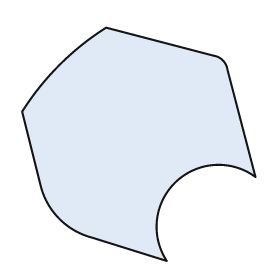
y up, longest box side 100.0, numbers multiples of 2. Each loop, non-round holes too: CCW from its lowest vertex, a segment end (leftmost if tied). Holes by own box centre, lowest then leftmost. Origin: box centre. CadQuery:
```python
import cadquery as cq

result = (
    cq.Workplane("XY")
    .moveTo(12.0, -50.0)
    .threePointArc((16.0, -16.0), (50.0, -14.0))
    .lineTo(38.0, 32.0)
    .threePointArc((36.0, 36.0), (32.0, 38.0))
    .lineTo(-14.0, 50.0)
    .threePointArc((-34.0, 34.0), (-50.0, 14.0))
    .lineTo(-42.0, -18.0)
    .threePointArc((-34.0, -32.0), (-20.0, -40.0))
    .close()
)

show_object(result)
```